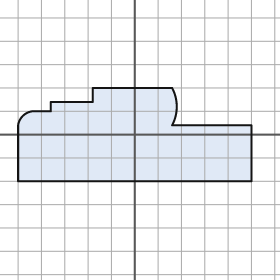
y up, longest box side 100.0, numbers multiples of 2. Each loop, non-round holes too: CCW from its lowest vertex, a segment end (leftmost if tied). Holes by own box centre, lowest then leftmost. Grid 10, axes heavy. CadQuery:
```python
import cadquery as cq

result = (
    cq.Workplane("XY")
    .moveTo(-50.0, -20.0)
    .lineTo(50.0, -20.0)
    .lineTo(50.0, 4.0)
    .lineTo(16.0, 4.0)
    .threePointArc((18.0, 12.0), (16.0, 20.0))
    .lineTo(-18.0, 20.0)
    .lineTo(-18.0, 14.0)
    .lineTo(-36.0, 14.0)
    .lineTo(-36.0, 10.0)
    .lineTo(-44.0, 10.0)
    .threePointArc((-48.0, 8.0), (-50.0, 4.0))
    .close()
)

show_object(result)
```